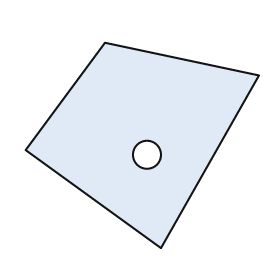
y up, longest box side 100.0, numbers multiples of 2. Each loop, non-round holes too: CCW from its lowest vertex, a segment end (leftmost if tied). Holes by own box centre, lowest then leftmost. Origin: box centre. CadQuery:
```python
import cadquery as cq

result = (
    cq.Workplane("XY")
    .moveTo(8.0, -44.0)
    .lineTo(50.0, 30.0)
    .lineTo(-16.0, 44.0)
    .lineTo(-50.0, -2.0)
    .close()
    .moveTo(2.0, -4.0)
    .circle(6.0)
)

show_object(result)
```